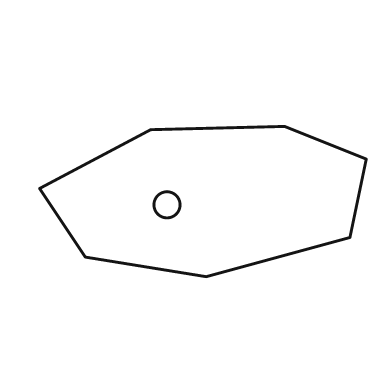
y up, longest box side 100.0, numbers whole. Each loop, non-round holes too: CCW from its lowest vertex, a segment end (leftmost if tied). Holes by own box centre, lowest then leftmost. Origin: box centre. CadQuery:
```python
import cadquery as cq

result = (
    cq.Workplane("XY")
    .moveTo(1.0, -23.0)
    .lineTo(45.0, -11.0)
    .lineTo(50.0, 13.0)
    .lineTo(25.0, 23.0)
    .lineTo(-16.0, 22.0)
    .lineTo(-50.0, 4.0)
    .lineTo(-36.0, -17.0)
    .close()
    .moveTo(-11.0, -1.0)
    .circle(4.0)
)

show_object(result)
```